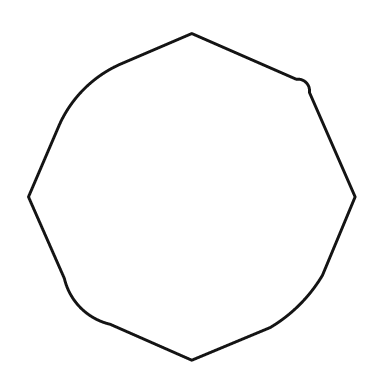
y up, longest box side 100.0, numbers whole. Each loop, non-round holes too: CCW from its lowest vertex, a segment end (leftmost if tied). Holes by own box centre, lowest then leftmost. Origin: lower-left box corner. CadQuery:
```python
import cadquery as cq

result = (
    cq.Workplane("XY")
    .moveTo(50.0, 0.0)
    .lineTo(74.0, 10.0)
    .threePointArc((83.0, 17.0), (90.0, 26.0))
    .lineTo(100.0, 50.0)
    .lineTo(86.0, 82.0)
    .threePointArc((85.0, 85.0), (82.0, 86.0))
    .lineTo(50.0, 100.0)
    .lineTo(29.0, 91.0)
    .threePointArc((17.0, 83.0), (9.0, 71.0))
    .lineTo(0.0, 50.0)
    .lineTo(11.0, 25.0)
    .threePointArc((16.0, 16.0), (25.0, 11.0))
    .close()
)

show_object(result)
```